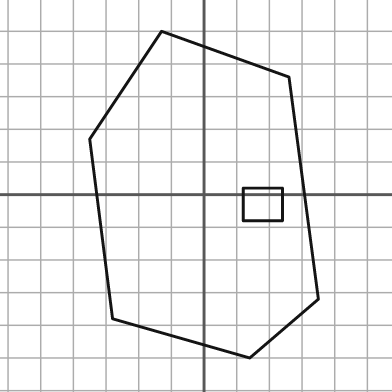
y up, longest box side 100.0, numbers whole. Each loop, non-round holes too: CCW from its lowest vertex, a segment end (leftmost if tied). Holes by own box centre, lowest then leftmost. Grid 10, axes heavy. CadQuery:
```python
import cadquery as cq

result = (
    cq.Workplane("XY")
    .moveTo(14.0, -50.0)
    .lineTo(35.0, -32.0)
    .lineTo(26.0, 36.0)
    .lineTo(-13.0, 50.0)
    .lineTo(-35.0, 17.0)
    .lineTo(-28.0, -38.0)
    .close()
    .moveTo(12.0, -8.0)
    .lineTo(24.0, -8.0)
    .lineTo(24.0, 2.0)
    .lineTo(12.0, 2.0)
    .close()
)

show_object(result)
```